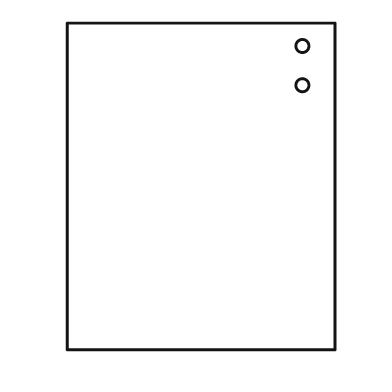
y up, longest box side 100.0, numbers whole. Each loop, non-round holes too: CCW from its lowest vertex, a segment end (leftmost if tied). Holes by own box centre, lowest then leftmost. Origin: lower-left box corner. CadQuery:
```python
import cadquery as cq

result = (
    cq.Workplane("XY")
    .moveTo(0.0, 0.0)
    .lineTo(82.0, 0.0)
    .lineTo(82.0, 100.0)
    .lineTo(0.0, 100.0)
    .close()
    .moveTo(72.0, 81.0)
    .circle(2.0)
    .moveTo(72.0, 93.0)
    .circle(2.0)
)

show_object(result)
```